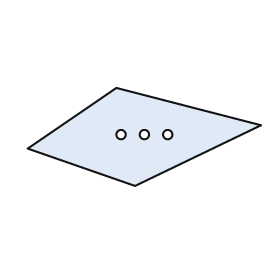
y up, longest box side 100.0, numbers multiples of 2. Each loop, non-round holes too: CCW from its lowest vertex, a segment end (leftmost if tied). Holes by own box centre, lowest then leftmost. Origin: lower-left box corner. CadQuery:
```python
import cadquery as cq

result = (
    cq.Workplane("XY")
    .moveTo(46.0, 0.0)
    .lineTo(100.0, 26.0)
    .lineTo(38.0, 42.0)
    .lineTo(0.0, 16.0)
    .close()
    .moveTo(40.0, 22.0)
    .circle(2.0)
    .moveTo(50.0, 22.0)
    .circle(2.0)
    .moveTo(60.0, 22.0)
    .circle(2.0)
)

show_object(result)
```